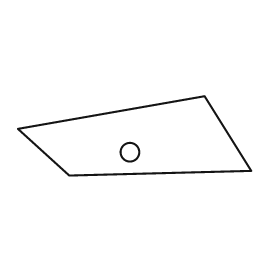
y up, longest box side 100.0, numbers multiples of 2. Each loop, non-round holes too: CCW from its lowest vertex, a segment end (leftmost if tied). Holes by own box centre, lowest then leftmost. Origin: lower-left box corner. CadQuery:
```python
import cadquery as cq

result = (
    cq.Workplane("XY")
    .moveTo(22.0, 0.0)
    .lineTo(100.0, 2.0)
    .lineTo(80.0, 34.0)
    .lineTo(0.0, 20.0)
    .close()
    .moveTo(48.0, 10.0)
    .circle(4.0)
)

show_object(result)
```